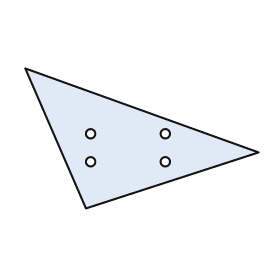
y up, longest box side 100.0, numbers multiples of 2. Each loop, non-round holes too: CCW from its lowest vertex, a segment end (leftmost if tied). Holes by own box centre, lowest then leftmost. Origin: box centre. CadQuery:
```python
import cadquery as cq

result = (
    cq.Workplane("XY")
    .moveTo(-24.0, -30.0)
    .lineTo(50.0, -6.0)
    .lineTo(-50.0, 30.0)
    .close()
    .moveTo(-22.0, -10.0)
    .circle(2.0)
    .moveTo(10.0, -10.0)
    .circle(2.0)
    .moveTo(-22.0, 2.0)
    .circle(2.0)
    .moveTo(10.0, 2.0)
    .circle(2.0)
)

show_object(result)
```